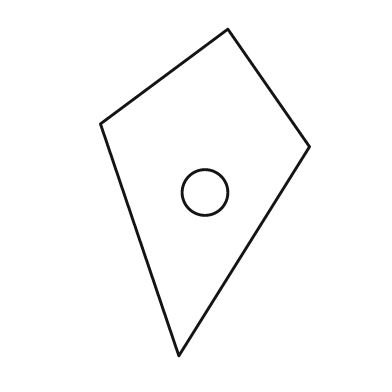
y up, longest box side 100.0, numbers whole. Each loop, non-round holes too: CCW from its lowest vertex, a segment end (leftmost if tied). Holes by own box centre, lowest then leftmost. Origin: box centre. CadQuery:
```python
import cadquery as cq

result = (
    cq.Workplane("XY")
    .moveTo(-8.0, -50.0)
    .lineTo(32.0, 14.0)
    .lineTo(7.0, 50.0)
    .lineTo(-32.0, 21.0)
    .close()
    .moveTo(0.0, 0.0)
    .circle(7.0)
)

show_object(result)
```